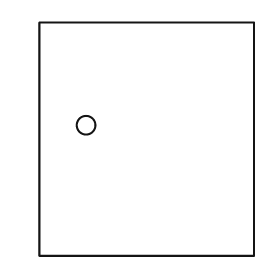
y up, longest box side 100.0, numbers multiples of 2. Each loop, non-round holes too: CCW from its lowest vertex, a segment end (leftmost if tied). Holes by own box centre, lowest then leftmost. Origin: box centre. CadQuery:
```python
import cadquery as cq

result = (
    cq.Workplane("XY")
    .moveTo(-46.0, -50.0)
    .lineTo(46.0, -50.0)
    .lineTo(46.0, 50.0)
    .lineTo(-46.0, 50.0)
    .close()
    .moveTo(-26.0, 6.0)
    .circle(4.0)
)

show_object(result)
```